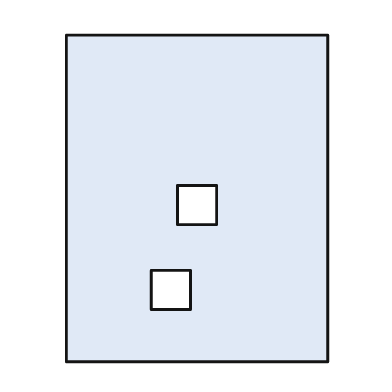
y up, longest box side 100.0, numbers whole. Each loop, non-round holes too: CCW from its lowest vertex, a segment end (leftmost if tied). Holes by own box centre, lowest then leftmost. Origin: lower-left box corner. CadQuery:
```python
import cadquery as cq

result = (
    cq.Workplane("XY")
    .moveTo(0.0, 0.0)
    .lineTo(80.0, 0.0)
    .lineTo(80.0, 100.0)
    .lineTo(0.0, 100.0)
    .close()
    .moveTo(26.0, 16.0)
    .lineTo(38.0, 16.0)
    .lineTo(38.0, 28.0)
    .lineTo(26.0, 28.0)
    .close()
    .moveTo(34.0, 42.0)
    .lineTo(46.0, 42.0)
    .lineTo(46.0, 54.0)
    .lineTo(34.0, 54.0)
    .close()
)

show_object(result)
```